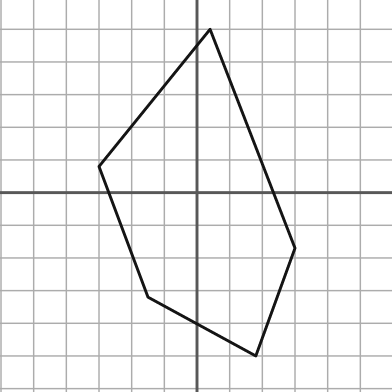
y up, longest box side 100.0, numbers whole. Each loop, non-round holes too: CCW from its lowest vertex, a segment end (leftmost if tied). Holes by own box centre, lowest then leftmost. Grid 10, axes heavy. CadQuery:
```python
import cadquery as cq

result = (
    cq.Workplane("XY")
    .moveTo(18.0, -50.0)
    .lineTo(30.0, -17.0)
    .lineTo(4.0, 50.0)
    .lineTo(-30.0, 8.0)
    .lineTo(-15.0, -32.0)
    .close()
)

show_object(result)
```